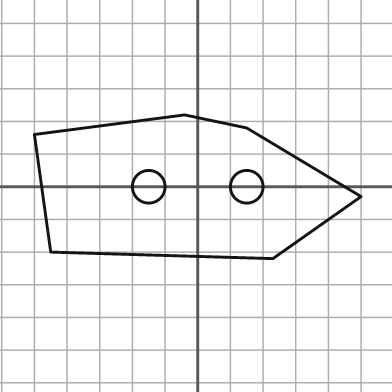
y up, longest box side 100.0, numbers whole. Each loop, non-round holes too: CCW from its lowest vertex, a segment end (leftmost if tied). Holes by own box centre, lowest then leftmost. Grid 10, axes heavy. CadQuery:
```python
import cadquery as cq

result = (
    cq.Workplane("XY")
    .moveTo(23.0, -22.0)
    .lineTo(50.0, -3.0)
    .lineTo(15.0, 18.0)
    .lineTo(-4.0, 22.0)
    .lineTo(-50.0, 16.0)
    .lineTo(-45.0, -20.0)
    .close()
    .moveTo(-15.0, 0.0)
    .circle(5.0)
    .moveTo(15.0, 0.0)
    .circle(5.0)
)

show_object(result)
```